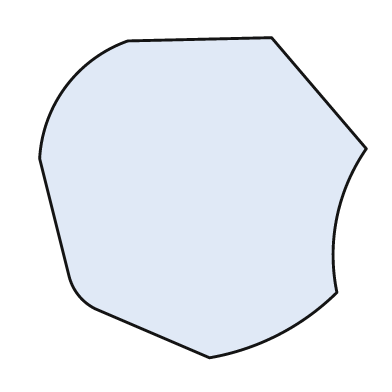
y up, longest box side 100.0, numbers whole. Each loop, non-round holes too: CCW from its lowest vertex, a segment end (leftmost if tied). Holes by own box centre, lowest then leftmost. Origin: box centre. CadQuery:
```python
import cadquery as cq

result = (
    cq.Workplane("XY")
    .moveTo(2.0, -49.0)
    .threePointArc((23.0, -42.0), (41.0, -29.0))
    .threePointArc((41.0, -6.0), (50.0, 15.0))
    .lineTo(21.0, 49.0)
    .lineTo(-23.0, 48.0)
    .threePointArc((-42.0, 34.0), (-50.0, 12.0))
    .lineTo(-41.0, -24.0)
    .threePointArc((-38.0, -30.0), (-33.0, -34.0))
    .close()
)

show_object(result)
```